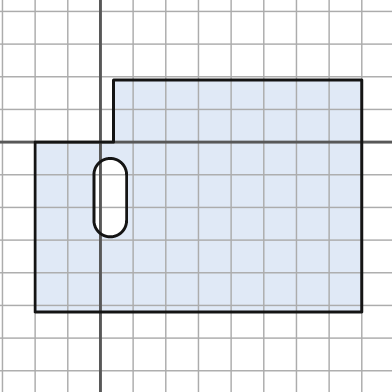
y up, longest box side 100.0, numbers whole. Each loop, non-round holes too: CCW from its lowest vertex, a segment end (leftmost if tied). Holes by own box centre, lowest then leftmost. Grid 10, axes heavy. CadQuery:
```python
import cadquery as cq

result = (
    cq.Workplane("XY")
    .moveTo(-20.0, -52.0)
    .lineTo(80.0, -52.0)
    .lineTo(80.0, 19.0)
    .lineTo(4.0, 19.0)
    .lineTo(4.0, 0.0)
    .lineTo(-20.0, 0.0)
    .close()
    .moveTo(-2.0, -24.0)
    .threePointArc((3.0, -29.0), (8.0, -24.0))
    .lineTo(8.0, -10.0)
    .threePointArc((3.0, -5.0), (-2.0, -10.0))
    .close()
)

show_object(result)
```